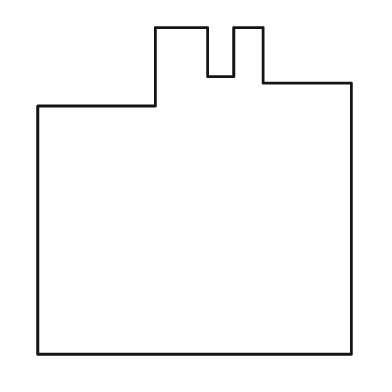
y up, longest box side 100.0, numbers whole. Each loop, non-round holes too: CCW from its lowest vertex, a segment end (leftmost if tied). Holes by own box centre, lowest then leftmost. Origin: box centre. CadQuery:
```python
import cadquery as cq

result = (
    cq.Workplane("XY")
    .moveTo(-48.0, -50.0)
    .lineTo(48.0, -50.0)
    .lineTo(48.0, 33.0)
    .lineTo(21.0, 33.0)
    .lineTo(21.0, 50.0)
    .lineTo(12.0, 50.0)
    .lineTo(12.0, 35.0)
    .lineTo(4.0, 35.0)
    .lineTo(4.0, 50.0)
    .lineTo(-12.0, 50.0)
    .lineTo(-12.0, 26.0)
    .lineTo(-48.0, 26.0)
    .close()
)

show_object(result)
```